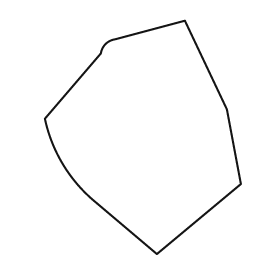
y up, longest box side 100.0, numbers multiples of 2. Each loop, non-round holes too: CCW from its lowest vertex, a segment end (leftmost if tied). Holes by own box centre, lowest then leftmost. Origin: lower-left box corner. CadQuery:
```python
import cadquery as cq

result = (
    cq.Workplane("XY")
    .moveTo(48.0, 0.0)
    .lineTo(84.0, 30.0)
    .lineTo(78.0, 62.0)
    .lineTo(60.0, 100.0)
    .lineTo(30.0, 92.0)
    .threePointArc((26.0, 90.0), (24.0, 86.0))
    .lineTo(0.0, 58.0)
    .threePointArc((8.0, 38.0), (22.0, 22.0))
    .close()
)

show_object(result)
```